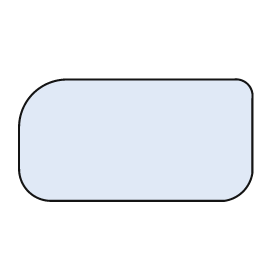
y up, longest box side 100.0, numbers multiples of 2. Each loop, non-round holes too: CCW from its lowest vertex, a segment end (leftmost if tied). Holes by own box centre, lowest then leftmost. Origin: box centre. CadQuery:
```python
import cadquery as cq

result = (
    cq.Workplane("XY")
    .moveTo(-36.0, -26.0)
    .lineTo(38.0, -26.0)
    .threePointArc((46.0, -22.0), (50.0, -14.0))
    .lineTo(50.0, 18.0)
    .threePointArc((48.0, 24.0), (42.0, 26.0))
    .lineTo(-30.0, 26.0)
    .threePointArc((-44.0, 20.0), (-50.0, 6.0))
    .lineTo(-50.0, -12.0)
    .threePointArc((-46.0, -22.0), (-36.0, -26.0))
    .close()
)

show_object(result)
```